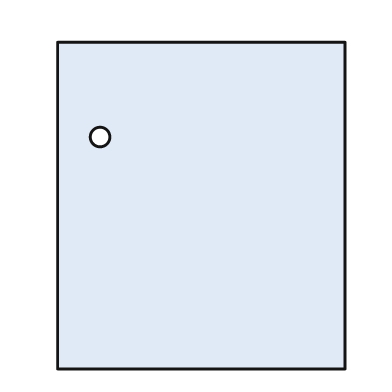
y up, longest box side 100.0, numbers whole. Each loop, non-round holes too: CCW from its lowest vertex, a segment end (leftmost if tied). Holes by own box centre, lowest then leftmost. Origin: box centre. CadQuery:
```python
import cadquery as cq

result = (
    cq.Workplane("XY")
    .moveTo(-44.0, -50.0)
    .lineTo(44.0, -50.0)
    .lineTo(44.0, 50.0)
    .lineTo(-44.0, 50.0)
    .close()
    .moveTo(-31.0, 21.0)
    .circle(3.0)
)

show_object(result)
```